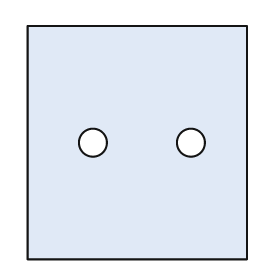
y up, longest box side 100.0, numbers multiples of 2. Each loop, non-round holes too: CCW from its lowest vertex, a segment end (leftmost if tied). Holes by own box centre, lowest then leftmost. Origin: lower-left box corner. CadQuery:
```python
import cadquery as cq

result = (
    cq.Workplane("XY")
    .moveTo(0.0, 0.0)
    .lineTo(94.0, 0.0)
    .lineTo(94.0, 100.0)
    .lineTo(0.0, 100.0)
    .close()
    .moveTo(28.0, 50.0)
    .circle(6.0)
    .moveTo(70.0, 50.0)
    .circle(6.0)
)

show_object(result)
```